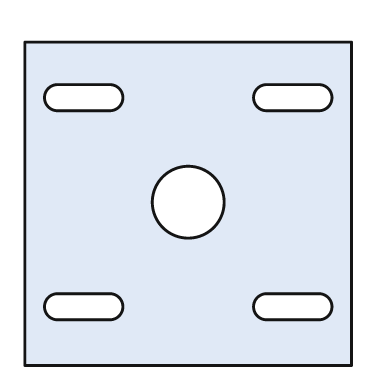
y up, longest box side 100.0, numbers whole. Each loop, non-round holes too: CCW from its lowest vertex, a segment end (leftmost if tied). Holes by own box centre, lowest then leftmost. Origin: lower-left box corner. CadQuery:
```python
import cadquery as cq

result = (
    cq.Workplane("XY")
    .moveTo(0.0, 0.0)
    .lineTo(100.0, 0.0)
    .lineTo(100.0, 99.0)
    .lineTo(0.0, 99.0)
    .close()
    .moveTo(10.0, 14.0)
    .lineTo(26.0, 14.0)
    .threePointArc((30.0, 18.0), (26.0, 22.0))
    .lineTo(10.0, 22.0)
    .threePointArc((6.0, 18.0), (10.0, 14.0))
    .close()
    .moveTo(74.0, 14.0)
    .lineTo(90.0, 14.0)
    .threePointArc((94.0, 18.0), (90.0, 22.0))
    .lineTo(74.0, 22.0)
    .threePointArc((70.0, 18.0), (74.0, 14.0))
    .close()
    .moveTo(50.0, 50.0)
    .circle(11.0)
    .moveTo(10.0, 78.0)
    .lineTo(26.0, 78.0)
    .threePointArc((30.0, 82.0), (26.0, 86.0))
    .lineTo(10.0, 86.0)
    .threePointArc((6.0, 82.0), (10.0, 78.0))
    .close()
    .moveTo(74.0, 78.0)
    .lineTo(90.0, 78.0)
    .threePointArc((94.0, 82.0), (90.0, 86.0))
    .lineTo(74.0, 86.0)
    .threePointArc((70.0, 82.0), (74.0, 78.0))
    .close()
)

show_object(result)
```